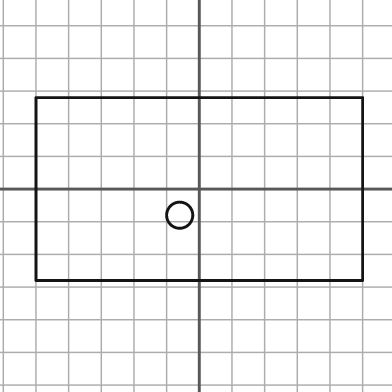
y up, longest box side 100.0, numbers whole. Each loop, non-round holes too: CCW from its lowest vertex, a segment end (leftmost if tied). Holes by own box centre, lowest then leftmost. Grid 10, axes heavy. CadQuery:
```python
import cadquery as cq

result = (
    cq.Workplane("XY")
    .moveTo(-50.0, -28.0)
    .lineTo(50.0, -28.0)
    .lineTo(50.0, 28.0)
    .lineTo(-50.0, 28.0)
    .close()
    .moveTo(-6.0, -8.0)
    .circle(4.0)
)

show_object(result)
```